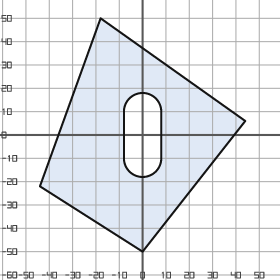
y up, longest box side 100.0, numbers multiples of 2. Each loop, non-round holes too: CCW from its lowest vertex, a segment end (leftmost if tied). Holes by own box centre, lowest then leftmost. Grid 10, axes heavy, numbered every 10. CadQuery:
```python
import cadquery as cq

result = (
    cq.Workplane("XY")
    .moveTo(0.0, -50.0)
    .lineTo(44.0, 6.0)
    .lineTo(-18.0, 50.0)
    .lineTo(-44.0, -22.0)
    .close()
    .moveTo(-8.0, -10.0)
    .threePointArc((0.0, -18.0), (8.0, -10.0))
    .lineTo(8.0, 10.0)
    .threePointArc((0.0, 18.0), (-8.0, 10.0))
    .close()
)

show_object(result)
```